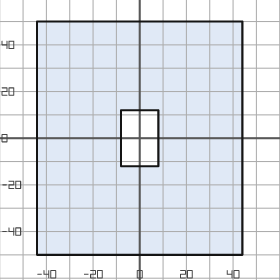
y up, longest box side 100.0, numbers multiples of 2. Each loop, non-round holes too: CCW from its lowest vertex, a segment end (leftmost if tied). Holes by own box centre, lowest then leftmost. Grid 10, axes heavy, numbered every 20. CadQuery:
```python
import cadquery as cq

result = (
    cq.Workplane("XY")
    .moveTo(-44.0, -50.0)
    .lineTo(44.0, -50.0)
    .lineTo(44.0, 50.0)
    .lineTo(-44.0, 50.0)
    .close()
    .moveTo(-8.0, -12.0)
    .lineTo(8.0, -12.0)
    .lineTo(8.0, 12.0)
    .lineTo(-8.0, 12.0)
    .close()
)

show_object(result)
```